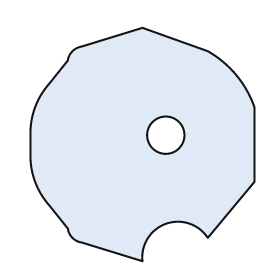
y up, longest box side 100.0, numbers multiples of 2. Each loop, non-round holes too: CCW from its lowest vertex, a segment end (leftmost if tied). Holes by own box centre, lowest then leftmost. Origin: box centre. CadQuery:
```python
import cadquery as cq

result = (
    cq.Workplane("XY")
    .moveTo(0.0, -50.0)
    .threePointArc((10.0, -34.0), (28.0, -40.0))
    .lineTo(48.0, -16.0)
    .lineTo(48.0, 16.0)
    .threePointArc((40.0, 30.0), (28.0, 40.0))
    .lineTo(0.0, 50.0)
    .lineTo(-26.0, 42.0)
    .threePointArc((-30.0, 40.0), (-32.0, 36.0))
    .lineTo(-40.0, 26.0)
    .threePointArc((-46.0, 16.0), (-48.0, 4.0))
    .lineTo(-48.0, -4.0)
    .threePointArc((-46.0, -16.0), (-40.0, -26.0))
    .lineTo(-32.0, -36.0)
    .threePointArc((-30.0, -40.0), (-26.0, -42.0))
    .close()
    .moveTo(10.0, 4.0)
    .circle(8.0)
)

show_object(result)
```